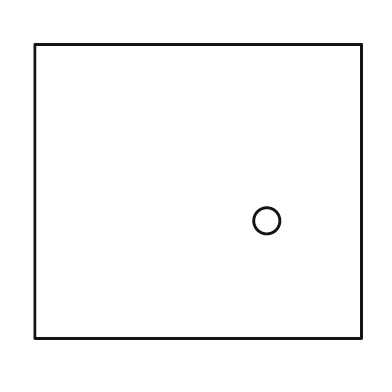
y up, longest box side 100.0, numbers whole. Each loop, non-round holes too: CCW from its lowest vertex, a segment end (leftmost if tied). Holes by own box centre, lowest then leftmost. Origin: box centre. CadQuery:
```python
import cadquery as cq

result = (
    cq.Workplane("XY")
    .moveTo(-50.0, -45.0)
    .lineTo(50.0, -45.0)
    .lineTo(50.0, 45.0)
    .lineTo(-50.0, 45.0)
    .close()
    .moveTo(21.0, -9.0)
    .circle(4.0)
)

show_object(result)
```